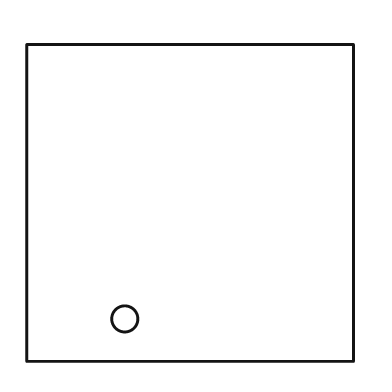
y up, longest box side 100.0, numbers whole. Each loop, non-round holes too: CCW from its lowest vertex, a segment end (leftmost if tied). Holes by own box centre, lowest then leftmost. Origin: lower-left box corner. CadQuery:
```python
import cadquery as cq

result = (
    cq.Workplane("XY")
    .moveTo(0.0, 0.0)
    .lineTo(100.0, 0.0)
    .lineTo(100.0, 97.0)
    .lineTo(0.0, 97.0)
    .close()
    .moveTo(30.0, 13.0)
    .circle(4.0)
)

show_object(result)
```